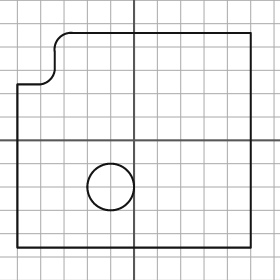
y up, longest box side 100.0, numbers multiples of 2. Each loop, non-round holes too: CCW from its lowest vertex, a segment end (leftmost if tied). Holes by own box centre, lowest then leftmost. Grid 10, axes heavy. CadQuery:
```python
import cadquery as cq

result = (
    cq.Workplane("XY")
    .moveTo(-50.0, -46.0)
    .lineTo(50.0, -46.0)
    .lineTo(50.0, 46.0)
    .lineTo(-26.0, 46.0)
    .threePointArc((-32.0, 44.0), (-34.0, 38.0))
    .lineTo(-34.0, 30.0)
    .threePointArc((-36.0, 26.0), (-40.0, 24.0))
    .lineTo(-50.0, 24.0)
    .close()
    .moveTo(-10.0, -20.0)
    .circle(10.0)
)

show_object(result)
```